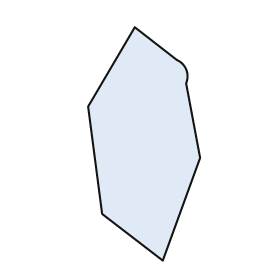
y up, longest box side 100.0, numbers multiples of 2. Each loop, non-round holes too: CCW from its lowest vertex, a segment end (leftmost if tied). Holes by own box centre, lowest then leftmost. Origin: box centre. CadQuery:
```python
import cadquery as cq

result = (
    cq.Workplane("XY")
    .moveTo(8.0, -50.0)
    .lineTo(24.0, -6.0)
    .lineTo(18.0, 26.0)
    .threePointArc((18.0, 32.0), (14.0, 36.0))
    .lineTo(-4.0, 50.0)
    .lineTo(-24.0, 16.0)
    .lineTo(-18.0, -30.0)
    .close()
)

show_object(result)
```